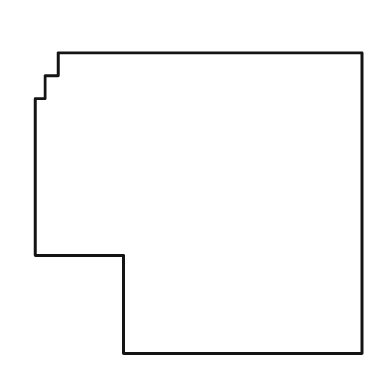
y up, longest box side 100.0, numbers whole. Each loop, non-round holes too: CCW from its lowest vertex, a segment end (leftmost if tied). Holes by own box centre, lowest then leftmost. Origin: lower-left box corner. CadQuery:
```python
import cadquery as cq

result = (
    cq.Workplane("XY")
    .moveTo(27.0, 0.0)
    .lineTo(100.0, 0.0)
    .lineTo(100.0, 92.0)
    .lineTo(7.0, 92.0)
    .lineTo(7.0, 85.0)
    .lineTo(3.0, 85.0)
    .lineTo(3.0, 78.0)
    .lineTo(0.0, 78.0)
    .lineTo(0.0, 30.0)
    .lineTo(27.0, 30.0)
    .close()
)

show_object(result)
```